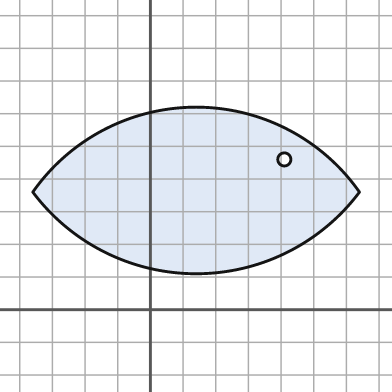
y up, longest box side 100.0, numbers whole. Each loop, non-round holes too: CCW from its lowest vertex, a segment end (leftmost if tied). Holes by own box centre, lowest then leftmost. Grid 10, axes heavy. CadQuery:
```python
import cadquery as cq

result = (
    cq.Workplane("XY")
    .moveTo(-36.0, 36.0)
    .threePointArc((14.0, 11.0), (64.0, 36.0))
    .threePointArc((14.0, 62.0), (-36.0, 36.0))
    .close()
    .moveTo(41.0, 46.0)
    .circle(2.0)
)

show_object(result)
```